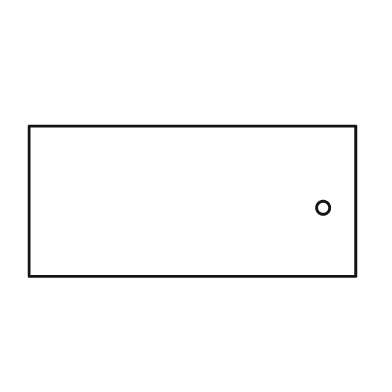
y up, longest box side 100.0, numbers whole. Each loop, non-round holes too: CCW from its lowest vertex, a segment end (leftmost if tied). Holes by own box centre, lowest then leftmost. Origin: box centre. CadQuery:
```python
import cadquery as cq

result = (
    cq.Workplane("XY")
    .moveTo(-50.0, -23.0)
    .lineTo(50.0, -23.0)
    .lineTo(50.0, 23.0)
    .lineTo(-50.0, 23.0)
    .close()
    .moveTo(40.0, -2.0)
    .circle(2.0)
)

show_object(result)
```